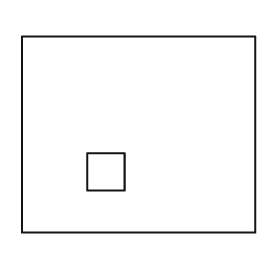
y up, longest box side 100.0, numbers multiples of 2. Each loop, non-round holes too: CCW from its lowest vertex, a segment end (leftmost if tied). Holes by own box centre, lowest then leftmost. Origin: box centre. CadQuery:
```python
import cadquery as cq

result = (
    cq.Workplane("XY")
    .moveTo(-50.0, -42.0)
    .lineTo(50.0, -42.0)
    .lineTo(50.0, 42.0)
    .lineTo(-50.0, 42.0)
    .close()
    .moveTo(-22.0, -24.0)
    .lineTo(-6.0, -24.0)
    .lineTo(-6.0, -8.0)
    .lineTo(-22.0, -8.0)
    .close()
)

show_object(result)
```